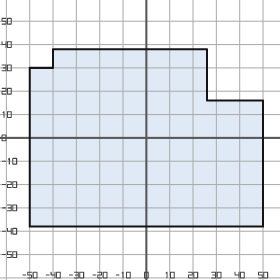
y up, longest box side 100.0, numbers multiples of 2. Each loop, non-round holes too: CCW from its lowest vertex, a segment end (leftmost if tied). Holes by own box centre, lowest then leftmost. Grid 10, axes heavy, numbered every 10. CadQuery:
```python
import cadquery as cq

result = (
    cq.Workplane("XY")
    .moveTo(-50.0, -38.0)
    .lineTo(50.0, -38.0)
    .lineTo(50.0, 16.0)
    .lineTo(26.0, 16.0)
    .lineTo(26.0, 38.0)
    .lineTo(-40.0, 38.0)
    .lineTo(-40.0, 30.0)
    .lineTo(-50.0, 30.0)
    .close()
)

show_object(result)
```